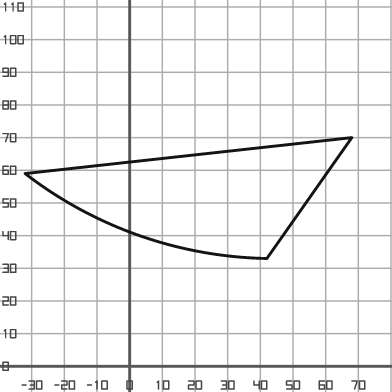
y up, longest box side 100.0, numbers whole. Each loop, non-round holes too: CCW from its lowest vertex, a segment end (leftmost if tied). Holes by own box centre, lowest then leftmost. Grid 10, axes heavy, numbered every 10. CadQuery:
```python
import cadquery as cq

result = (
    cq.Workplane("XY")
    .moveTo(42.0, 33.0)
    .lineTo(68.0, 70.0)
    .lineTo(-32.0, 59.0)
    .threePointArc((3.0, 40.0), (42.0, 33.0))
    .close()
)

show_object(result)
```